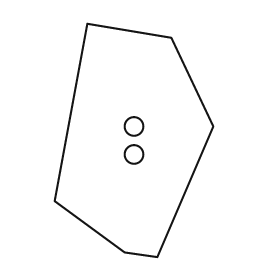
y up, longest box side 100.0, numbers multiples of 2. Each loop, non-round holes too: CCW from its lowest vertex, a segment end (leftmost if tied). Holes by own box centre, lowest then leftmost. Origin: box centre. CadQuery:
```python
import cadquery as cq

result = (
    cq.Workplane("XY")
    .moveTo(10.0, -50.0)
    .lineTo(34.0, 6.0)
    .lineTo(16.0, 44.0)
    .lineTo(-20.0, 50.0)
    .lineTo(-34.0, -26.0)
    .lineTo(-4.0, -48.0)
    .close()
    .moveTo(0.0, -6.0)
    .circle(4.0)
    .moveTo(0.0, 6.0)
    .circle(4.0)
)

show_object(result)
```